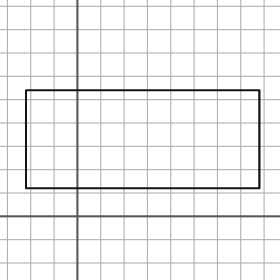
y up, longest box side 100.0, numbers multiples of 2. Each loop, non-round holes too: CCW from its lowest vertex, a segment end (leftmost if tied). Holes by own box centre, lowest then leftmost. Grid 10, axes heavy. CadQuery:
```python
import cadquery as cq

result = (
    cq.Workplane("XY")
    .moveTo(-22.0, 12.0)
    .lineTo(78.0, 12.0)
    .lineTo(78.0, 54.0)
    .lineTo(-22.0, 54.0)
    .close()
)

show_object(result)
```